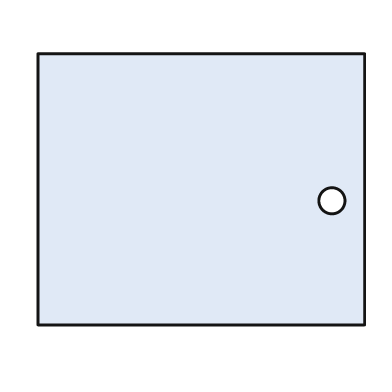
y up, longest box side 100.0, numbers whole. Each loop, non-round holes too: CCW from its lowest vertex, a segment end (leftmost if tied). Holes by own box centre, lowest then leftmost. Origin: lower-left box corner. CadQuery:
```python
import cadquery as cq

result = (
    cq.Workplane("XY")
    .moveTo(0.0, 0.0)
    .lineTo(100.0, 0.0)
    .lineTo(100.0, 83.0)
    .lineTo(0.0, 83.0)
    .close()
    .moveTo(90.0, 38.0)
    .circle(4.0)
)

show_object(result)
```